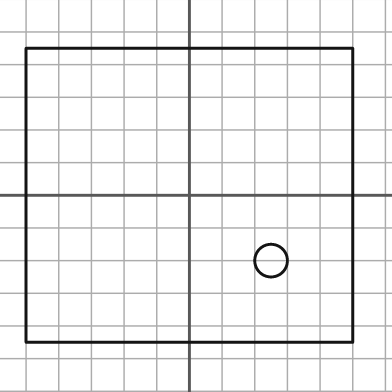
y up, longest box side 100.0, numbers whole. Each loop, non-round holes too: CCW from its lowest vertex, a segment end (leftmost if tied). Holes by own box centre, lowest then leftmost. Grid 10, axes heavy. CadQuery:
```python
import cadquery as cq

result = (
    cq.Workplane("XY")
    .moveTo(-50.0, -45.0)
    .lineTo(50.0, -45.0)
    .lineTo(50.0, 45.0)
    .lineTo(-50.0, 45.0)
    .close()
    .moveTo(25.0, -20.0)
    .circle(5.0)
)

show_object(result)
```